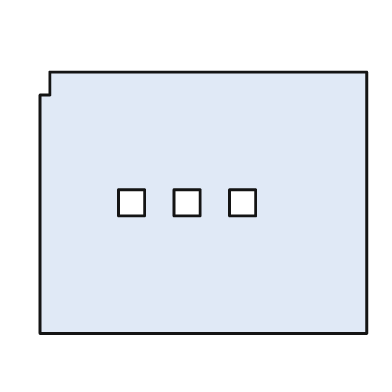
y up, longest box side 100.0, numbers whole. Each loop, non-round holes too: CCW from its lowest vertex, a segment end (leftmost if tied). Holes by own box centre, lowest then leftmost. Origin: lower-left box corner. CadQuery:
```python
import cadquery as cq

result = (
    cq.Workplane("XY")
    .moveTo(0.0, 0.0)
    .lineTo(100.0, 0.0)
    .lineTo(100.0, 80.0)
    .lineTo(3.0, 80.0)
    .lineTo(3.0, 73.0)
    .lineTo(0.0, 73.0)
    .close()
    .moveTo(24.0, 36.0)
    .lineTo(32.0, 36.0)
    .lineTo(32.0, 44.0)
    .lineTo(24.0, 44.0)
    .close()
    .moveTo(41.0, 36.0)
    .lineTo(49.0, 36.0)
    .lineTo(49.0, 44.0)
    .lineTo(41.0, 44.0)
    .close()
    .moveTo(58.0, 36.0)
    .lineTo(66.0, 36.0)
    .lineTo(66.0, 44.0)
    .lineTo(58.0, 44.0)
    .close()
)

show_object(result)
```